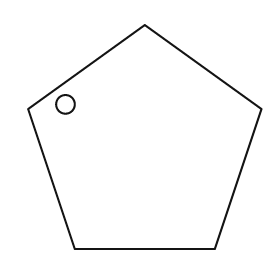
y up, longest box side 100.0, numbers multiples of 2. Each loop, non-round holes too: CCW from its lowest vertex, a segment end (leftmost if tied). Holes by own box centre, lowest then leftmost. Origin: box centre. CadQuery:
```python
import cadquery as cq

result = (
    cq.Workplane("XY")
    .moveTo(-30.0, -48.0)
    .lineTo(30.0, -48.0)
    .lineTo(50.0, 12.0)
    .lineTo(0.0, 48.0)
    .lineTo(-50.0, 12.0)
    .close()
    .moveTo(-34.0, 14.0)
    .circle(4.0)
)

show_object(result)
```